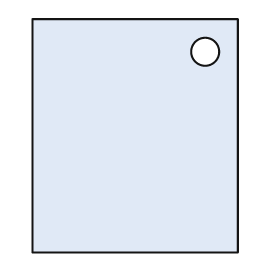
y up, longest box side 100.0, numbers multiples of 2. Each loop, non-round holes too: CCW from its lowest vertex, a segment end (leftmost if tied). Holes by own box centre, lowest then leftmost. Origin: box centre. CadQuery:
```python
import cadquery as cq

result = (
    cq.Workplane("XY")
    .moveTo(-44.0, -50.0)
    .lineTo(44.0, -50.0)
    .lineTo(44.0, 50.0)
    .lineTo(-44.0, 50.0)
    .close()
    .moveTo(30.0, 36.0)
    .circle(6.0)
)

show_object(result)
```